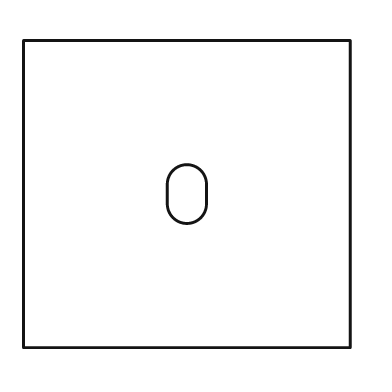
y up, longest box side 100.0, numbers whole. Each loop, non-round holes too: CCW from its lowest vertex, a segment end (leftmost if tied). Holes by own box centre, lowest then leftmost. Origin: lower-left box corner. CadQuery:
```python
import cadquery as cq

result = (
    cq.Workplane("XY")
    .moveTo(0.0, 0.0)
    .lineTo(100.0, 0.0)
    .lineTo(100.0, 94.0)
    .lineTo(0.0, 94.0)
    .close()
    .moveTo(44.0, 44.0)
    .threePointArc((50.0, 38.0), (56.0, 44.0))
    .lineTo(56.0, 50.0)
    .threePointArc((50.0, 56.0), (44.0, 50.0))
    .close()
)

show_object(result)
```